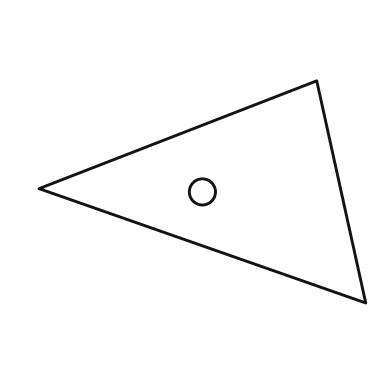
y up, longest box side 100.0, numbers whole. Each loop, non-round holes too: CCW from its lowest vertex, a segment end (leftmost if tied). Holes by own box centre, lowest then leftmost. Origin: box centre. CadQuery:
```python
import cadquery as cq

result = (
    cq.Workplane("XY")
    .moveTo(50.0, -34.0)
    .lineTo(35.0, 34.0)
    .lineTo(-50.0, 1.0)
    .close()
    .moveTo(0.0, 0.0)
    .circle(4.0)
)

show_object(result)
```